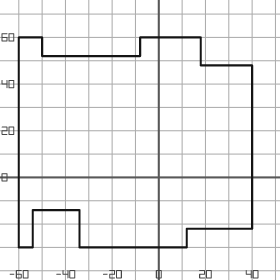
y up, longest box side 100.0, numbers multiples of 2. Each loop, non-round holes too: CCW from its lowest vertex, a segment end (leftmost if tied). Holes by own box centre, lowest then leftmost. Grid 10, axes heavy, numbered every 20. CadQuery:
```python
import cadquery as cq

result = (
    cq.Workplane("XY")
    .moveTo(-60.0, -30.0)
    .lineTo(-54.0, -30.0)
    .lineTo(-54.0, -14.0)
    .lineTo(-34.0, -14.0)
    .lineTo(-34.0, -30.0)
    .lineTo(12.0, -30.0)
    .lineTo(12.0, -22.0)
    .lineTo(40.0, -22.0)
    .lineTo(40.0, 48.0)
    .lineTo(18.0, 48.0)
    .lineTo(18.0, 60.0)
    .lineTo(-8.0, 60.0)
    .lineTo(-8.0, 52.0)
    .lineTo(-50.0, 52.0)
    .lineTo(-50.0, 60.0)
    .lineTo(-60.0, 60.0)
    .close()
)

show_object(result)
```